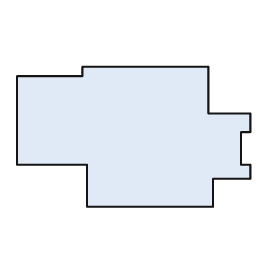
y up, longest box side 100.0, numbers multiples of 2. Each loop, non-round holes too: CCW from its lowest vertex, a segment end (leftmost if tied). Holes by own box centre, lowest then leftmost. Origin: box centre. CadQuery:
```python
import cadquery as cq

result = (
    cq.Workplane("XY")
    .moveTo(-20.0, -30.0)
    .lineTo(34.0, -30.0)
    .lineTo(34.0, -18.0)
    .lineTo(50.0, -18.0)
    .lineTo(50.0, -12.0)
    .lineTo(46.0, -12.0)
    .lineTo(46.0, 2.0)
    .lineTo(50.0, 2.0)
    .lineTo(50.0, 10.0)
    .lineTo(32.0, 10.0)
    .lineTo(32.0, 30.0)
    .lineTo(-22.0, 30.0)
    .lineTo(-22.0, 26.0)
    .lineTo(-50.0, 26.0)
    .lineTo(-50.0, -12.0)
    .lineTo(-20.0, -12.0)
    .close()
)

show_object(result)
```